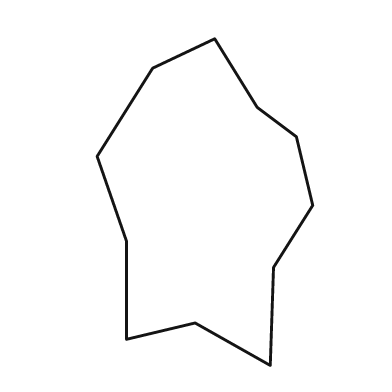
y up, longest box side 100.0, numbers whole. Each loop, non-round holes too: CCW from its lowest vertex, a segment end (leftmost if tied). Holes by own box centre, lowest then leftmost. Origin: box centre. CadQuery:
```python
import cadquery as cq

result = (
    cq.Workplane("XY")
    .moveTo(20.0, -50.0)
    .lineTo(21.0, -20.0)
    .lineTo(33.0, -1.0)
    .lineTo(28.0, 20.0)
    .lineTo(16.0, 29.0)
    .lineTo(3.0, 50.0)
    .lineTo(-16.0, 41.0)
    .lineTo(-33.0, 14.0)
    .lineTo(-24.0, -12.0)
    .lineTo(-24.0, -42.0)
    .lineTo(-3.0, -37.0)
    .close()
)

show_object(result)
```